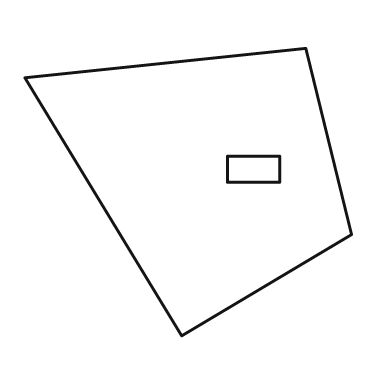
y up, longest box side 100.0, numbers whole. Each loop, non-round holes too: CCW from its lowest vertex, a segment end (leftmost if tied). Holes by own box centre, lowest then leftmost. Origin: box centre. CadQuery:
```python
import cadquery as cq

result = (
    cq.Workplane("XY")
    .moveTo(-2.0, -44.0)
    .lineTo(50.0, -13.0)
    .lineTo(36.0, 44.0)
    .lineTo(-50.0, 35.0)
    .close()
    .moveTo(12.0, 3.0)
    .lineTo(28.0, 3.0)
    .lineTo(28.0, 11.0)
    .lineTo(12.0, 11.0)
    .close()
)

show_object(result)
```